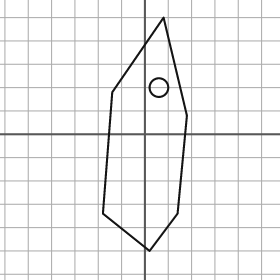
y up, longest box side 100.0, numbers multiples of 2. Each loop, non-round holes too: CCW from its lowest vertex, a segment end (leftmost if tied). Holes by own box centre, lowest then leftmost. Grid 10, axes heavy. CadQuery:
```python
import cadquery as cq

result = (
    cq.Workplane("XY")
    .moveTo(2.0, -50.0)
    .lineTo(14.0, -34.0)
    .lineTo(18.0, 8.0)
    .lineTo(8.0, 50.0)
    .lineTo(-14.0, 18.0)
    .lineTo(-18.0, -34.0)
    .close()
    .moveTo(6.0, 20.0)
    .circle(4.0)
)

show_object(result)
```